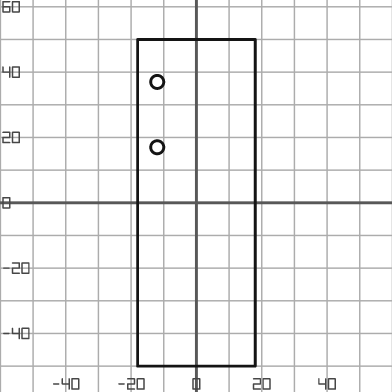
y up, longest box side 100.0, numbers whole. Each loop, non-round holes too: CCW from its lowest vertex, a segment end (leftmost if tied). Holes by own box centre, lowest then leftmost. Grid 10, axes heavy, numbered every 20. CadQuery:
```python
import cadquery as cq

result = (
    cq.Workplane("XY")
    .moveTo(-18.0, -50.0)
    .lineTo(18.0, -50.0)
    .lineTo(18.0, 50.0)
    .lineTo(-18.0, 50.0)
    .close()
    .moveTo(-12.0, 17.0)
    .circle(2.0)
    .moveTo(-12.0, 37.0)
    .circle(2.0)
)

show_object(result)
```